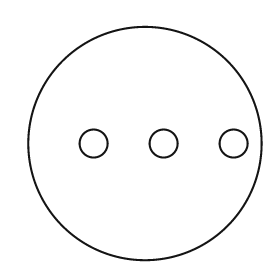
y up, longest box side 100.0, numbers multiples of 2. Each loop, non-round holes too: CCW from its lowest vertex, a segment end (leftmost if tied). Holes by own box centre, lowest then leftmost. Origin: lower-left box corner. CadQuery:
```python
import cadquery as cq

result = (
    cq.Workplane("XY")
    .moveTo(50.0, 50.0)
    .circle(50.0)
    .moveTo(28.0, 50.0)
    .circle(6.0)
    .moveTo(58.0, 50.0)
    .circle(6.0)
    .moveTo(88.0, 50.0)
    .circle(6.0)
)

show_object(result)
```